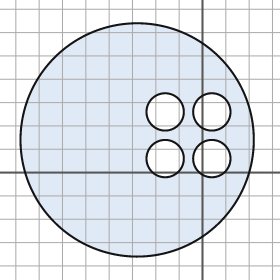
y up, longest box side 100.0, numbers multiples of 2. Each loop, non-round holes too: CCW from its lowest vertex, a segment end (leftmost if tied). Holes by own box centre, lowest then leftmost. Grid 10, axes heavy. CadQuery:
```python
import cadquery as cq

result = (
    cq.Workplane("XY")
    .moveTo(-28.0, 14.0)
    .circle(50.0)
    .moveTo(-16.0, 6.0)
    .circle(8.0)
    .moveTo(4.0, 6.0)
    .circle(8.0)
    .moveTo(-16.0, 26.0)
    .circle(8.0)
    .moveTo(4.0, 26.0)
    .circle(8.0)
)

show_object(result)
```